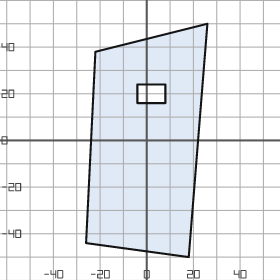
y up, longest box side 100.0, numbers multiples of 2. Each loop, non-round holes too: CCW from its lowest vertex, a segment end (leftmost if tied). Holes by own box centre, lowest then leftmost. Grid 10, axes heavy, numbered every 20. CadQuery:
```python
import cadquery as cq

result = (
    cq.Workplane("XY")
    .moveTo(18.0, -50.0)
    .lineTo(26.0, 50.0)
    .lineTo(-22.0, 38.0)
    .lineTo(-26.0, -44.0)
    .close()
    .moveTo(-4.0, 16.0)
    .lineTo(8.0, 16.0)
    .lineTo(8.0, 24.0)
    .lineTo(-4.0, 24.0)
    .close()
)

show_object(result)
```